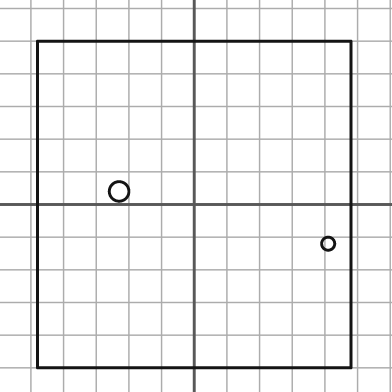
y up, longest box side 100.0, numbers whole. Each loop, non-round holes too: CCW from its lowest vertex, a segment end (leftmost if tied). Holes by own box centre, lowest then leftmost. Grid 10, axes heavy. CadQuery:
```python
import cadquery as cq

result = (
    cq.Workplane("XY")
    .moveTo(-48.0, -50.0)
    .lineTo(48.0, -50.0)
    .lineTo(48.0, 50.0)
    .lineTo(-48.0, 50.0)
    .close()
    .moveTo(41.0, -12.0)
    .circle(2.0)
    .moveTo(-23.0, 4.0)
    .circle(3.0)
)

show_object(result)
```